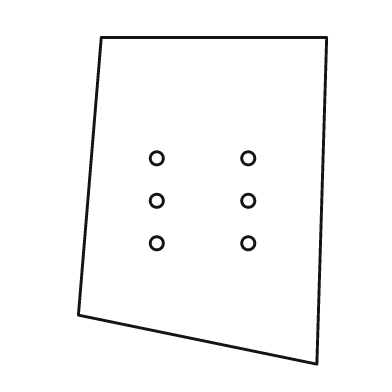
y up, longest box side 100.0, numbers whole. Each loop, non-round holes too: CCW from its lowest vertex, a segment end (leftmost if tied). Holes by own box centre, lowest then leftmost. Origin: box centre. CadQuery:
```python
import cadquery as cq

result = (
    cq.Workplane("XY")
    .moveTo(35.0, -50.0)
    .lineTo(38.0, 50.0)
    .lineTo(-31.0, 50.0)
    .lineTo(-38.0, -35.0)
    .close()
    .moveTo(-14.0, -13.0)
    .circle(2.0)
    .moveTo(14.0, -13.0)
    .circle(2.0)
    .moveTo(-14.0, 0.0)
    .circle(2.0)
    .moveTo(14.0, 0.0)
    .circle(2.0)
    .moveTo(-14.0, 13.0)
    .circle(2.0)
    .moveTo(14.0, 13.0)
    .circle(2.0)
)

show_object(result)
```